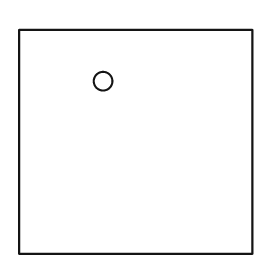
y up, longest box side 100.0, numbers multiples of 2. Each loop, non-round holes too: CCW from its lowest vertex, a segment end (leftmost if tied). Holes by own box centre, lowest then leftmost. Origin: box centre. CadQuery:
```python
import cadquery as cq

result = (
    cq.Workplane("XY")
    .moveTo(-50.0, -48.0)
    .lineTo(50.0, -48.0)
    .lineTo(50.0, 48.0)
    .lineTo(-50.0, 48.0)
    .close()
    .moveTo(-14.0, 26.0)
    .circle(4.0)
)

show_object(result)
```